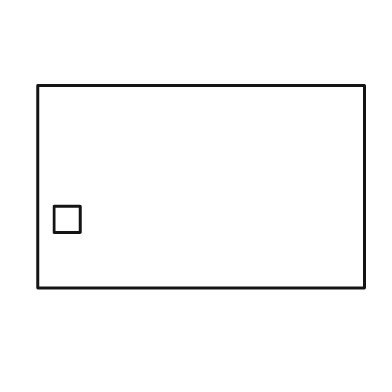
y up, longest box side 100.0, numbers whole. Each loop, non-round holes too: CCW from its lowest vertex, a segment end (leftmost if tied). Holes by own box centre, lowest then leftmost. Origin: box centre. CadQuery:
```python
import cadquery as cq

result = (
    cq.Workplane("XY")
    .moveTo(-50.0, -31.0)
    .lineTo(50.0, -31.0)
    .lineTo(50.0, 31.0)
    .lineTo(-50.0, 31.0)
    .close()
    .moveTo(-45.0, -14.0)
    .lineTo(-37.0, -14.0)
    .lineTo(-37.0, -6.0)
    .lineTo(-45.0, -6.0)
    .close()
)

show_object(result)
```